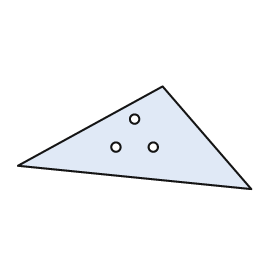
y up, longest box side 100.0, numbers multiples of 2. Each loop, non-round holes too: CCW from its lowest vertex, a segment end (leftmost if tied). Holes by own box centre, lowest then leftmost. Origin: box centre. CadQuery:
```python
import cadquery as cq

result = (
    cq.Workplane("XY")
    .moveTo(50.0, -22.0)
    .lineTo(12.0, 22.0)
    .lineTo(-50.0, -12.0)
    .close()
    .moveTo(-8.0, -4.0)
    .circle(2.0)
    .moveTo(8.0, -4.0)
    .circle(2.0)
    .moveTo(0.0, 8.0)
    .circle(2.0)
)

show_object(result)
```